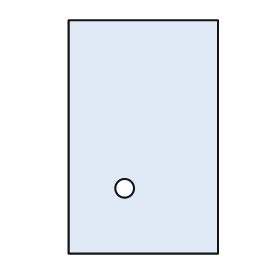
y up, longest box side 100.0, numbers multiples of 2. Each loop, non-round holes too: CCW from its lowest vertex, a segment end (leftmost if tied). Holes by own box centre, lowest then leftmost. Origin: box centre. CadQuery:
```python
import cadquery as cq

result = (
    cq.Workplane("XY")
    .moveTo(-32.0, -50.0)
    .lineTo(32.0, -50.0)
    .lineTo(32.0, 50.0)
    .lineTo(-32.0, 50.0)
    .close()
    .moveTo(-8.0, -22.0)
    .circle(4.0)
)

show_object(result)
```